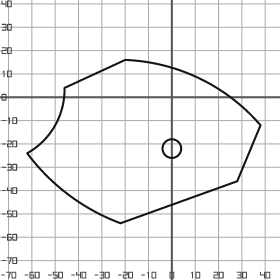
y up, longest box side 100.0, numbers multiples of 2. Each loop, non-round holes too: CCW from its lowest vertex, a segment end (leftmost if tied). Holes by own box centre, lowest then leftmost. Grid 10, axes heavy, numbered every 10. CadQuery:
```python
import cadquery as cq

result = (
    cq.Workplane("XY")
    .moveTo(-22.0, -54.0)
    .lineTo(28.0, -36.0)
    .lineTo(38.0, -12.0)
    .threePointArc((12.0, 8.0), (-20.0, 16.0))
    .lineTo(-46.0, 4.0)
    .threePointArc((-50.0, -12.0), (-62.0, -24.0))
    .threePointArc((-44.0, -42.0), (-22.0, -54.0))
    .close()
    .moveTo(0.0, -22.0)
    .circle(4.0)
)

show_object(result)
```